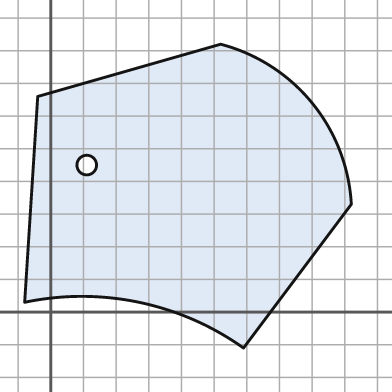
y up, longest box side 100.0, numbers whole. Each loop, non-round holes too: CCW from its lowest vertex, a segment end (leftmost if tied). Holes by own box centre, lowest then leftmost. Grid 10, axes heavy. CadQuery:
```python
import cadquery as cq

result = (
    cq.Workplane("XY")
    .moveTo(59.0, -11.0)
    .lineTo(92.0, 33.0)
    .threePointArc((80.0, 64.0), (52.0, 82.0))
    .lineTo(-4.0, 66.0)
    .lineTo(-8.0, 3.0)
    .threePointArc((27.0, 3.0), (59.0, -11.0))
    .close()
    .moveTo(11.0, 45.0)
    .circle(3.0)
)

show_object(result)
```